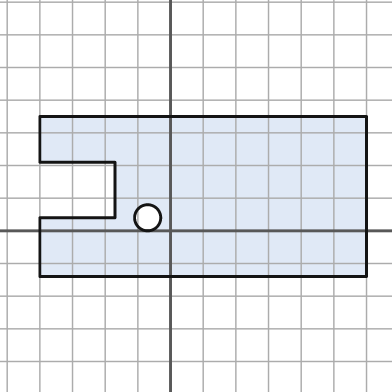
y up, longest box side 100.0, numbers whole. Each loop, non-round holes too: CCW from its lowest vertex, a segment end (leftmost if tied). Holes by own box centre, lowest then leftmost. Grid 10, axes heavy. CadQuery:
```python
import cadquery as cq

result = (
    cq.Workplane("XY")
    .moveTo(-40.0, -14.0)
    .lineTo(60.0, -14.0)
    .lineTo(60.0, 35.0)
    .lineTo(-40.0, 35.0)
    .lineTo(-40.0, 21.0)
    .lineTo(-17.0, 21.0)
    .lineTo(-17.0, 4.0)
    .lineTo(-40.0, 4.0)
    .close()
    .moveTo(-7.0, 4.0)
    .circle(4.0)
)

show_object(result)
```